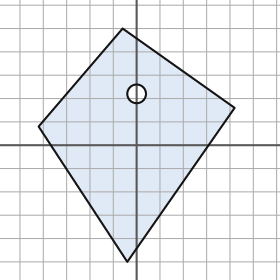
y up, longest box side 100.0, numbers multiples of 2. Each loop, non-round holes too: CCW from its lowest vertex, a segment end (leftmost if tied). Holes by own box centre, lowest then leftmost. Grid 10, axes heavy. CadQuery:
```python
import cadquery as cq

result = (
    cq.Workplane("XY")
    .moveTo(-4.0, -50.0)
    .lineTo(42.0, 16.0)
    .lineTo(-6.0, 50.0)
    .lineTo(-42.0, 8.0)
    .close()
    .moveTo(0.0, 22.0)
    .circle(4.0)
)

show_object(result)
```